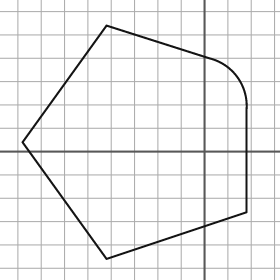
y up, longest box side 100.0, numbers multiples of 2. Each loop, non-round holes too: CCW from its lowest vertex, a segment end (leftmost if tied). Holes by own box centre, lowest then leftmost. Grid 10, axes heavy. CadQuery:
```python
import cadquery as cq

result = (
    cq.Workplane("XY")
    .moveTo(-42.0, -46.0)
    .lineTo(18.0, -26.0)
    .lineTo(18.0, 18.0)
    .threePointArc((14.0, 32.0), (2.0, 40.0))
    .lineTo(-42.0, 54.0)
    .lineTo(-78.0, 4.0)
    .close()
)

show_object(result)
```